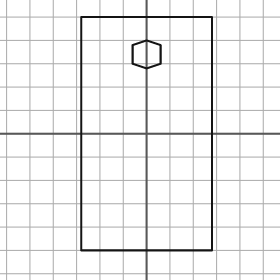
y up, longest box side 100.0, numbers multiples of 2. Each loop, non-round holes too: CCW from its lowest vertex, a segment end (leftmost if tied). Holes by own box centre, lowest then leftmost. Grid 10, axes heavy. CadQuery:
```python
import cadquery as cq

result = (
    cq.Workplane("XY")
    .moveTo(-28.0, -50.0)
    .lineTo(28.0, -50.0)
    .lineTo(28.0, 50.0)
    .lineTo(-28.0, 50.0)
    .close()
    .moveTo(0.0, 28.0)
    .lineTo(6.0, 30.0)
    .lineTo(6.0, 38.0)
    .lineTo(0.0, 40.0)
    .lineTo(-6.0, 38.0)
    .lineTo(-6.0, 30.0)
    .close()
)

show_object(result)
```